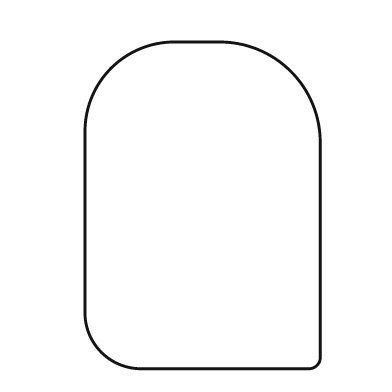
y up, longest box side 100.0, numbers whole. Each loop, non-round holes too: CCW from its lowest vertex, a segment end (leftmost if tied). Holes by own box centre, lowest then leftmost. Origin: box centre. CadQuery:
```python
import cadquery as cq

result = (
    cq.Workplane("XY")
    .moveTo(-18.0, -50.0)
    .lineTo(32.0, -50.0)
    .threePointArc((35.0, -49.0), (36.0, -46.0))
    .lineTo(36.0, 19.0)
    .threePointArc((27.0, 41.0), (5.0, 50.0))
    .lineTo(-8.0, 50.0)
    .threePointArc((-28.0, 42.0), (-36.0, 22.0))
    .lineTo(-36.0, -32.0)
    .threePointArc((-31.0, -45.0), (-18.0, -50.0))
    .close()
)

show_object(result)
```